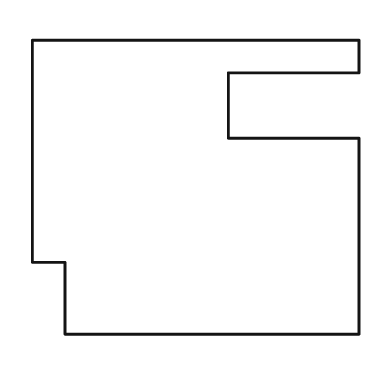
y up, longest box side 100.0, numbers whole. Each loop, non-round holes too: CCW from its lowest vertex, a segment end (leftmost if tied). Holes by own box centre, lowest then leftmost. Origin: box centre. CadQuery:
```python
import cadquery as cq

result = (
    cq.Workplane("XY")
    .moveTo(-40.0, -45.0)
    .lineTo(50.0, -45.0)
    .lineTo(50.0, 15.0)
    .lineTo(10.0, 15.0)
    .lineTo(10.0, 35.0)
    .lineTo(50.0, 35.0)
    .lineTo(50.0, 45.0)
    .lineTo(-50.0, 45.0)
    .lineTo(-50.0, -23.0)
    .lineTo(-40.0, -23.0)
    .close()
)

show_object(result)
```